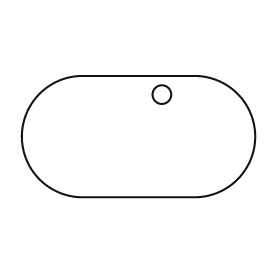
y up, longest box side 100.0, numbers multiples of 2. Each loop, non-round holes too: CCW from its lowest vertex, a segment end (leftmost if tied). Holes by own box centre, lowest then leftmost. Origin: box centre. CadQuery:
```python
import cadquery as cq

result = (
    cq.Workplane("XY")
    .moveTo(-24.0, -26.0)
    .lineTo(24.0, -26.0)
    .threePointArc((50.0, 0.0), (24.0, 26.0))
    .lineTo(-24.0, 26.0)
    .threePointArc((-50.0, 0.0), (-24.0, -26.0))
    .close()
    .moveTo(10.0, 18.0)
    .circle(4.0)
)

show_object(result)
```